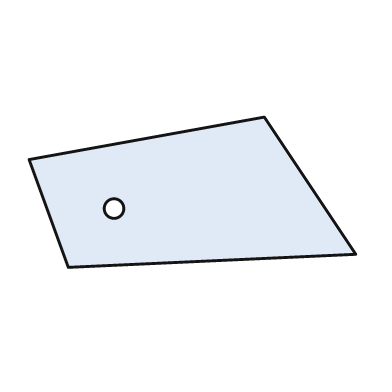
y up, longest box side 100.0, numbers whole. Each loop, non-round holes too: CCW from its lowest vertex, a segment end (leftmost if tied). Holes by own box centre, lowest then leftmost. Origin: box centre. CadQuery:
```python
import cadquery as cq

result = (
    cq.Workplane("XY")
    .moveTo(-38.0, -23.0)
    .lineTo(50.0, -19.0)
    .lineTo(22.0, 23.0)
    .lineTo(-50.0, 10.0)
    .close()
    .moveTo(-24.0, -5.0)
    .circle(3.0)
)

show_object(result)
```